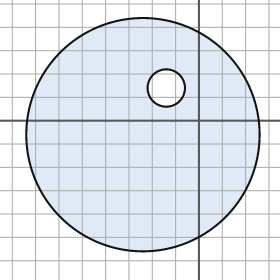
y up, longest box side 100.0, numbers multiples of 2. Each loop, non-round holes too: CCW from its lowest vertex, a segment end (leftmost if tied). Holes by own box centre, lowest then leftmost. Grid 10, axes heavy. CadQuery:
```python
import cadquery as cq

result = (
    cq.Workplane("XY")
    .moveTo(-24.0, -6.0)
    .circle(50.0)
    .moveTo(-14.0, 14.0)
    .circle(8.0)
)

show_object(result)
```